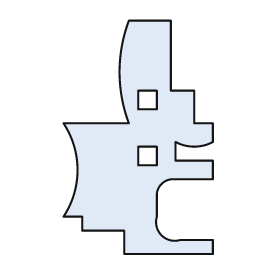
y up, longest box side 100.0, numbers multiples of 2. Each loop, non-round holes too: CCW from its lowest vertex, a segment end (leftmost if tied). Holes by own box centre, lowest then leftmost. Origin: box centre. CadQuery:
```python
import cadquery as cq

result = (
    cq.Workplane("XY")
    .moveTo(-6.0, -50.0)
    .lineTo(32.0, -50.0)
    .lineTo(32.0, -44.0)
    .lineTo(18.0, -44.0)
    .threePointArc((10.0, -42.0), (8.0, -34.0))
    .lineTo(8.0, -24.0)
    .threePointArc((10.0, -20.0), (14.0, -18.0))
    .lineTo(32.0, -18.0)
    .lineTo(32.0, -10.0)
    .lineTo(16.0, -10.0)
    .lineTo(16.0, -2.0)
    .threePointArc((24.0, -4.0), (32.0, -2.0))
    .lineTo(32.0, 6.0)
    .lineTo(24.0, 6.0)
    .lineTo(24.0, 20.0)
    .lineTo(14.0, 20.0)
    .lineTo(14.0, 50.0)
    .lineTo(-4.0, 50.0)
    .threePointArc((-8.0, 28.0), (-4.0, 6.0))
    .lineTo(-32.0, 6.0)
    .threePointArc((-26.0, -14.0), (-32.0, -34.0))
    .lineTo(-24.0, -34.0)
    .lineTo(-24.0, -40.0)
    .lineTo(-6.0, -40.0)
    .close()
    .moveTo(0.0, -12.0)
    .lineTo(8.0, -12.0)
    .lineTo(8.0, -4.0)
    .lineTo(0.0, -4.0)
    .close()
    .moveTo(0.0, 12.0)
    .lineTo(8.0, 12.0)
    .lineTo(8.0, 20.0)
    .lineTo(0.0, 20.0)
    .close()
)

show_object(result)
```